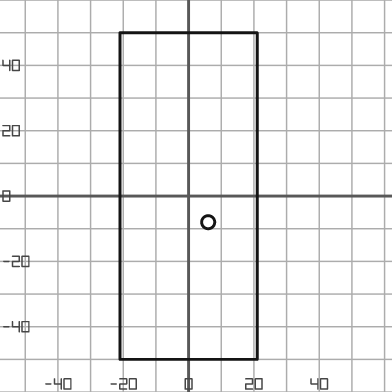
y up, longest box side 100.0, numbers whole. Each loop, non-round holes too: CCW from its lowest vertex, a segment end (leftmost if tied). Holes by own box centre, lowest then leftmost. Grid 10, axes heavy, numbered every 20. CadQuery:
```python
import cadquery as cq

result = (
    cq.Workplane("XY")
    .moveTo(-21.0, -50.0)
    .lineTo(21.0, -50.0)
    .lineTo(21.0, 50.0)
    .lineTo(-21.0, 50.0)
    .close()
    .moveTo(6.0, -8.0)
    .circle(2.0)
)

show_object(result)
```